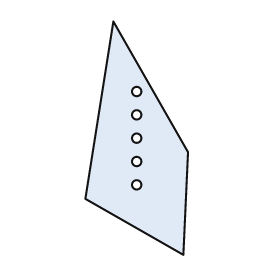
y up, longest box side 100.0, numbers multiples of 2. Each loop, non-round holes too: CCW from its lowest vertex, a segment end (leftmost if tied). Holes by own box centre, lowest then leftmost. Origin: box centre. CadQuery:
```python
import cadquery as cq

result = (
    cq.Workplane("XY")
    .moveTo(20.0, -50.0)
    .lineTo(22.0, -6.0)
    .lineTo(-10.0, 50.0)
    .lineTo(-22.0, -26.0)
    .close()
    .moveTo(0.0, -20.0)
    .circle(2.0)
    .moveTo(0.0, -10.0)
    .circle(2.0)
    .moveTo(0.0, 0.0)
    .circle(2.0)
    .moveTo(0.0, 10.0)
    .circle(2.0)
    .moveTo(0.0, 20.0)
    .circle(2.0)
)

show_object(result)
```